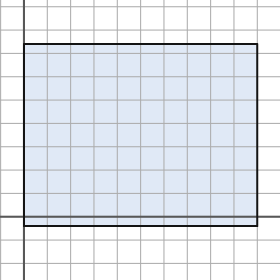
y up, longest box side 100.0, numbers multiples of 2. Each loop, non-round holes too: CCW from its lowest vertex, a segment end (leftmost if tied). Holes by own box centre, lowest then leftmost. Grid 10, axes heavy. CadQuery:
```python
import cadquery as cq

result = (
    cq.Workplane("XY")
    .moveTo(0.0, -4.0)
    .lineTo(100.0, -4.0)
    .lineTo(100.0, 74.0)
    .lineTo(0.0, 74.0)
    .close()
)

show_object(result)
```